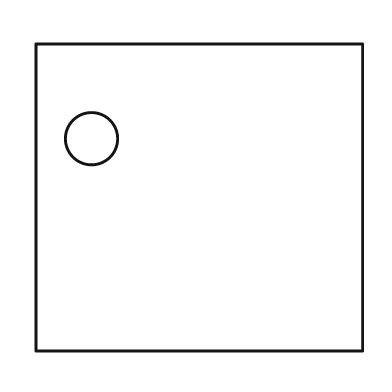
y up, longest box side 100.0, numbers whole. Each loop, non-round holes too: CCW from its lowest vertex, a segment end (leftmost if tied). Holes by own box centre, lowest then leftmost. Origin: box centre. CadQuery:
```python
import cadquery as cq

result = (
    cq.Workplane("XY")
    .moveTo(-50.0, -47.0)
    .lineTo(50.0, -47.0)
    .lineTo(50.0, 47.0)
    .lineTo(-50.0, 47.0)
    .close()
    .moveTo(-33.0, 18.0)
    .circle(8.0)
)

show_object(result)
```